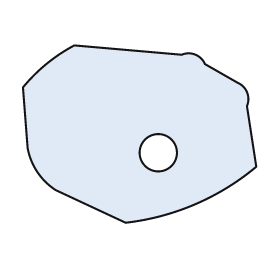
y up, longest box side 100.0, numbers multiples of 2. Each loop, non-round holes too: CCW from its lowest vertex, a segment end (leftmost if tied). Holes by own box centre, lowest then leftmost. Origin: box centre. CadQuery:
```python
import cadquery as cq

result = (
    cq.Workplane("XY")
    .moveTo(-6.0, -38.0)
    .threePointArc((24.0, -30.0), (50.0, -14.0))
    .lineTo(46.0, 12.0)
    .threePointArc((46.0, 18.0), (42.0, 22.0))
    .lineTo(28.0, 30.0)
    .threePointArc((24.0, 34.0), (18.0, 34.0))
    .lineTo(-28.0, 38.0)
    .threePointArc((-40.0, 30.0), (-50.0, 20.0))
    .lineTo(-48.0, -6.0)
    .threePointArc((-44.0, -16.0), (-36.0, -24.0))
    .close()
    .moveTo(8.0, -8.0)
    .circle(8.0)
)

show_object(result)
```